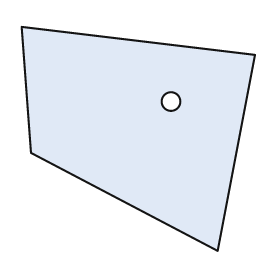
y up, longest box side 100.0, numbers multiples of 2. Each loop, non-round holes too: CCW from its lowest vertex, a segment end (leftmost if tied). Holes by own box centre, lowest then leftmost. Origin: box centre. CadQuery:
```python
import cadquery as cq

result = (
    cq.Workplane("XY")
    .moveTo(34.0, -48.0)
    .lineTo(50.0, 36.0)
    .lineTo(-50.0, 48.0)
    .lineTo(-46.0, -6.0)
    .close()
    .moveTo(14.0, 16.0)
    .circle(4.0)
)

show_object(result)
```